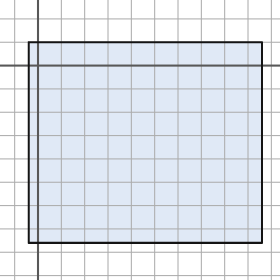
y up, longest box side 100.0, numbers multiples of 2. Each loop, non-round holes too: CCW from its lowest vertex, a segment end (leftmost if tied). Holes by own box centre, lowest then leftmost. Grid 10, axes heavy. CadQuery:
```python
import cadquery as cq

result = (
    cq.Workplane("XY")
    .moveTo(-4.0, -76.0)
    .lineTo(96.0, -76.0)
    .lineTo(96.0, 10.0)
    .lineTo(-4.0, 10.0)
    .close()
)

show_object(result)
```